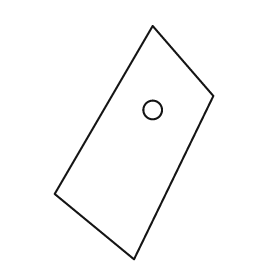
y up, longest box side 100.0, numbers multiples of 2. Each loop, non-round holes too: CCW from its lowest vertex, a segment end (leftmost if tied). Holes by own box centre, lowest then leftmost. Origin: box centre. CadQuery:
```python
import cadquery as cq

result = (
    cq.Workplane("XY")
    .moveTo(0.0, -50.0)
    .lineTo(34.0, 20.0)
    .lineTo(8.0, 50.0)
    .lineTo(-34.0, -22.0)
    .close()
    .moveTo(8.0, 14.0)
    .circle(4.0)
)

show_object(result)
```